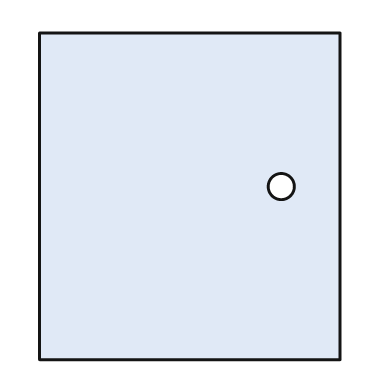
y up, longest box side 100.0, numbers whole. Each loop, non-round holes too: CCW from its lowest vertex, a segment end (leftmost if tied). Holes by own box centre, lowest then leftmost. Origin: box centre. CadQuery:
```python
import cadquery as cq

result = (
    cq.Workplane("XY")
    .moveTo(-46.0, -50.0)
    .lineTo(46.0, -50.0)
    .lineTo(46.0, 50.0)
    .lineTo(-46.0, 50.0)
    .close()
    .moveTo(28.0, 3.0)
    .circle(4.0)
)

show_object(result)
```